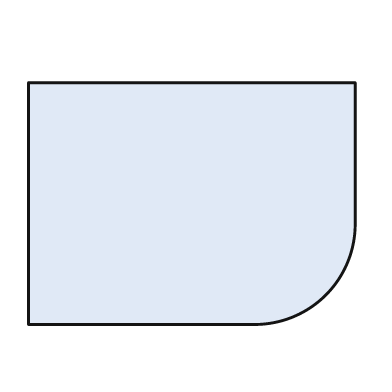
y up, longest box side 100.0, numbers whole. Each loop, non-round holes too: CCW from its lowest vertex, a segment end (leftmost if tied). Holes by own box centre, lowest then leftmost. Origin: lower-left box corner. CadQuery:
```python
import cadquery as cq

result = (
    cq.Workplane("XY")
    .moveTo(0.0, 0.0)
    .lineTo(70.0, 0.0)
    .threePointArc((91.0, 9.0), (100.0, 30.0))
    .lineTo(100.0, 74.0)
    .lineTo(0.0, 74.0)
    .close()
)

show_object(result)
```